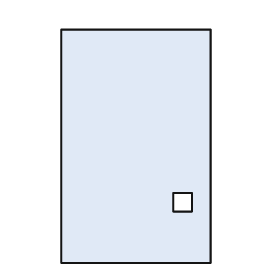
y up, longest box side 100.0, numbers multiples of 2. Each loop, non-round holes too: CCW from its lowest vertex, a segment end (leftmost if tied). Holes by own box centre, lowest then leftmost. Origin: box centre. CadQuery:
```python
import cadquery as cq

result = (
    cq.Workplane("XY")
    .moveTo(-32.0, -50.0)
    .lineTo(32.0, -50.0)
    .lineTo(32.0, 50.0)
    .lineTo(-32.0, 50.0)
    .close()
    .moveTo(16.0, -28.0)
    .lineTo(24.0, -28.0)
    .lineTo(24.0, -20.0)
    .lineTo(16.0, -20.0)
    .close()
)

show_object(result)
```